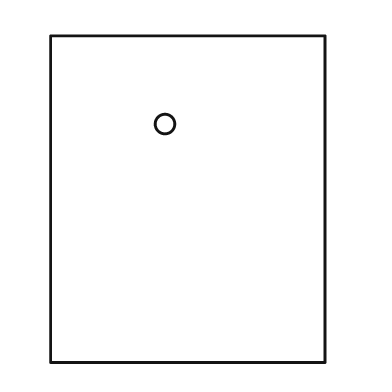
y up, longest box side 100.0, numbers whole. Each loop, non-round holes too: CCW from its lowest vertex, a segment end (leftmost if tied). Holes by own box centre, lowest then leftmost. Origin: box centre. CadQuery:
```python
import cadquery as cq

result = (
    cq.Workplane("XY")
    .moveTo(-42.0, -50.0)
    .lineTo(42.0, -50.0)
    .lineTo(42.0, 50.0)
    .lineTo(-42.0, 50.0)
    .close()
    .moveTo(-7.0, 23.0)
    .circle(3.0)
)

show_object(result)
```